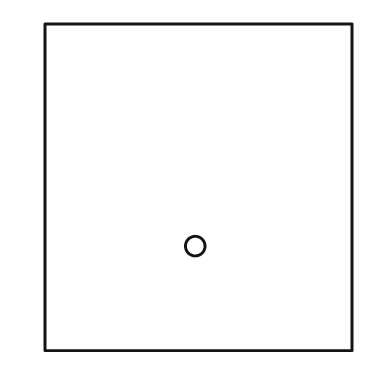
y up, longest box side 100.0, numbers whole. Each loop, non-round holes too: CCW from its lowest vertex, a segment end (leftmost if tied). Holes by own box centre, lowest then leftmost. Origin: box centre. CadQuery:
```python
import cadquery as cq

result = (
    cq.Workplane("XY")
    .moveTo(-47.0, -50.0)
    .lineTo(47.0, -50.0)
    .lineTo(47.0, 50.0)
    .lineTo(-47.0, 50.0)
    .close()
    .moveTo(-1.0, -18.0)
    .circle(3.0)
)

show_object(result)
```